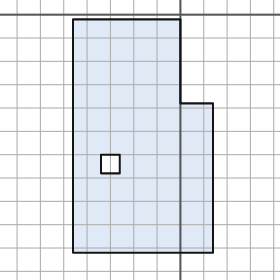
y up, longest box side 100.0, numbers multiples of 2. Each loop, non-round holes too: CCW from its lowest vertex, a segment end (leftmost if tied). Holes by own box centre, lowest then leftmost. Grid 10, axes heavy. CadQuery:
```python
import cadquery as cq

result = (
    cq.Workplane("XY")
    .moveTo(-46.0, -102.0)
    .lineTo(14.0, -102.0)
    .lineTo(14.0, -38.0)
    .lineTo(0.0, -38.0)
    .lineTo(0.0, -2.0)
    .lineTo(-46.0, -2.0)
    .close()
    .moveTo(-34.0, -68.0)
    .lineTo(-26.0, -68.0)
    .lineTo(-26.0, -60.0)
    .lineTo(-34.0, -60.0)
    .close()
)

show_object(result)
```